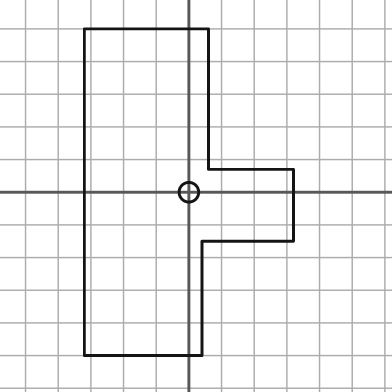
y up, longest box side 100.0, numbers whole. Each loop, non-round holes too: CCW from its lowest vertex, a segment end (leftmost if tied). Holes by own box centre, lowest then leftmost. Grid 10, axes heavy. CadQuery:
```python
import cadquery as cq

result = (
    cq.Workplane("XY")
    .moveTo(-32.0, -50.0)
    .lineTo(4.0, -50.0)
    .lineTo(4.0, -15.0)
    .lineTo(32.0, -15.0)
    .lineTo(32.0, 7.0)
    .lineTo(6.0, 7.0)
    .lineTo(6.0, 50.0)
    .lineTo(-32.0, 50.0)
    .close()
    .moveTo(0.0, 0.0)
    .circle(3.0)
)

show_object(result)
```